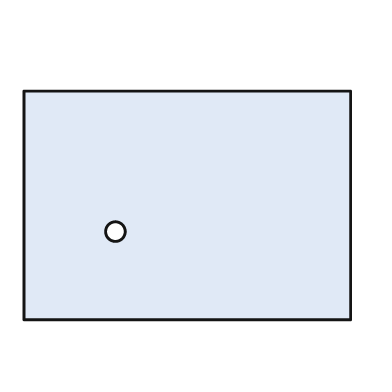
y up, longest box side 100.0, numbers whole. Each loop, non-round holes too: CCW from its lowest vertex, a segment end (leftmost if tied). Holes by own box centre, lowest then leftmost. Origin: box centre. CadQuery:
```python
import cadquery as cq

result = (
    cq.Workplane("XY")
    .moveTo(-50.0, -35.0)
    .lineTo(50.0, -35.0)
    .lineTo(50.0, 35.0)
    .lineTo(-50.0, 35.0)
    .close()
    .moveTo(-22.0, -8.0)
    .circle(3.0)
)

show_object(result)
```